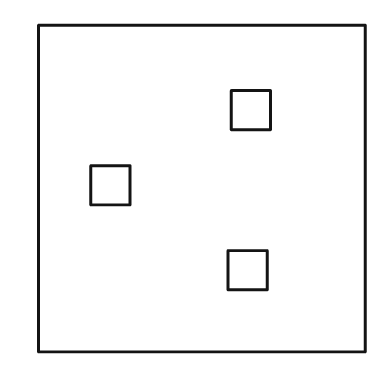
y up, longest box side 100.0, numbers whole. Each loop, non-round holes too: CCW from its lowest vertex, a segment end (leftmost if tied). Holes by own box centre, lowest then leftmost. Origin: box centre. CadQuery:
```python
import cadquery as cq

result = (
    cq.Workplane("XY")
    .moveTo(-50.0, -50.0)
    .lineTo(50.0, -50.0)
    .lineTo(50.0, 50.0)
    .lineTo(-50.0, 50.0)
    .close()
    .moveTo(8.0, -31.0)
    .lineTo(20.0, -31.0)
    .lineTo(20.0, -19.0)
    .lineTo(8.0, -19.0)
    .close()
    .moveTo(-34.0, -5.0)
    .lineTo(-22.0, -5.0)
    .lineTo(-22.0, 7.0)
    .lineTo(-34.0, 7.0)
    .close()
    .moveTo(9.0, 18.0)
    .lineTo(21.0, 18.0)
    .lineTo(21.0, 30.0)
    .lineTo(9.0, 30.0)
    .close()
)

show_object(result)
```